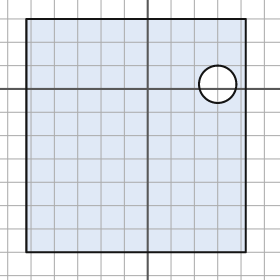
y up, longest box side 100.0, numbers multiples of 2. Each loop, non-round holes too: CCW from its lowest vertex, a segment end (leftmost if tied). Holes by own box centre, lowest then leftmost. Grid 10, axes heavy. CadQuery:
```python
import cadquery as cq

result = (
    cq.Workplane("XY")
    .moveTo(-52.0, -70.0)
    .lineTo(42.0, -70.0)
    .lineTo(42.0, 30.0)
    .lineTo(-52.0, 30.0)
    .close()
    .moveTo(30.0, 2.0)
    .circle(8.0)
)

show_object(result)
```